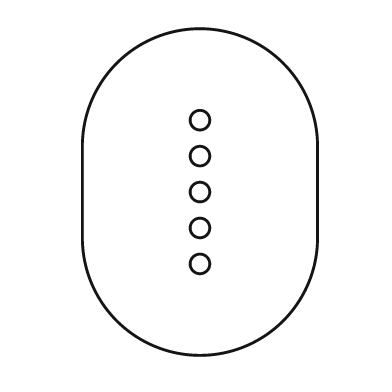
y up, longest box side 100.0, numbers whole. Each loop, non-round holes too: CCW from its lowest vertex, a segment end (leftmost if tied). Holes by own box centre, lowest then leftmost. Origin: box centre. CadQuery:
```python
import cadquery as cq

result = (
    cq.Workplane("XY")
    .moveTo(-36.0, -14.0)
    .threePointArc((0.0, -50.0), (36.0, -14.0))
    .lineTo(36.0, 14.0)
    .threePointArc((0.0, 50.0), (-36.0, 14.0))
    .close()
    .moveTo(0.0, -22.0)
    .circle(3.0)
    .moveTo(0.0, -11.0)
    .circle(3.0)
    .moveTo(0.0, 0.0)
    .circle(3.0)
    .moveTo(0.0, 11.0)
    .circle(3.0)
    .moveTo(0.0, 22.0)
    .circle(3.0)
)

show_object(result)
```